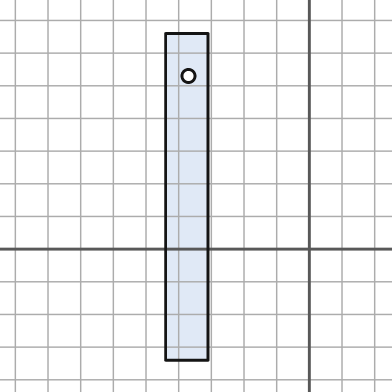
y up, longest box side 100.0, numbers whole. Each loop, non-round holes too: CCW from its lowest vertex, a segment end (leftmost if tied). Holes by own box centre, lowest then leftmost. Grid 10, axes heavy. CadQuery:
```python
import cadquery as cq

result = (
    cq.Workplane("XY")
    .moveTo(-44.0, -34.0)
    .lineTo(-31.0, -34.0)
    .lineTo(-31.0, 66.0)
    .lineTo(-44.0, 66.0)
    .close()
    .moveTo(-37.0, 53.0)
    .circle(2.0)
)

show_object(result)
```